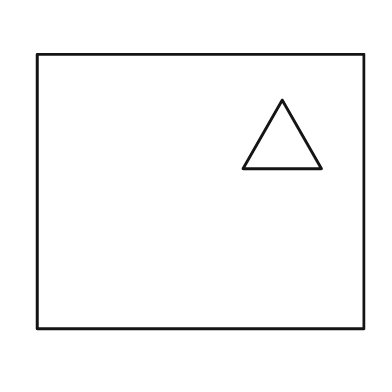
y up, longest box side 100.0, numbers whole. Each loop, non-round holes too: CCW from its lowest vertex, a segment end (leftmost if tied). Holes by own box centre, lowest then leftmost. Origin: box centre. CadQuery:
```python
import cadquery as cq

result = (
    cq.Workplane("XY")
    .moveTo(-50.0, -42.0)
    .lineTo(50.0, -42.0)
    .lineTo(50.0, 42.0)
    .lineTo(-50.0, 42.0)
    .close()
    .moveTo(13.0, 7.0)
    .lineTo(37.0, 7.0)
    .lineTo(25.0, 28.0)
    .close()
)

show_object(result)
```